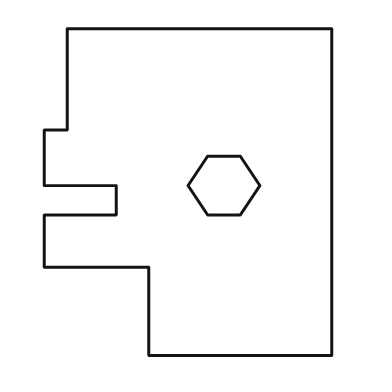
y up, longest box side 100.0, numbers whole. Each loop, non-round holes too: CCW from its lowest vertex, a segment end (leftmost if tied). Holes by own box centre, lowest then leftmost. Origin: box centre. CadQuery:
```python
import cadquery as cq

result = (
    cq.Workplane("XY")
    .moveTo(-12.0, -50.0)
    .lineTo(44.0, -50.0)
    .lineTo(44.0, 50.0)
    .lineTo(-37.0, 50.0)
    .lineTo(-37.0, 19.0)
    .lineTo(-44.0, 19.0)
    .lineTo(-44.0, 2.0)
    .lineTo(-22.0, 2.0)
    .lineTo(-22.0, -7.0)
    .lineTo(-44.0, -7.0)
    .lineTo(-44.0, -23.0)
    .lineTo(-12.0, -23.0)
    .close()
    .moveTo(6.0, -7.0)
    .lineTo(16.0, -7.0)
    .lineTo(22.0, 2.0)
    .lineTo(16.0, 11.0)
    .lineTo(6.0, 11.0)
    .lineTo(0.0, 2.0)
    .close()
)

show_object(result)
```